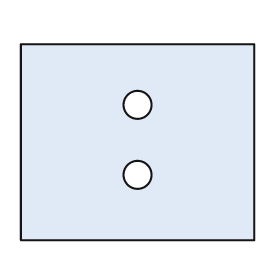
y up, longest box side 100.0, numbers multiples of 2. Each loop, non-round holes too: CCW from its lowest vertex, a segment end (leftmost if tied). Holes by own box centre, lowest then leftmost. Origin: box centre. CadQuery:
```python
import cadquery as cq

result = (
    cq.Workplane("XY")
    .moveTo(-50.0, -42.0)
    .lineTo(50.0, -42.0)
    .lineTo(50.0, 42.0)
    .lineTo(-50.0, 42.0)
    .close()
    .moveTo(0.0, -14.0)
    .circle(6.0)
    .moveTo(0.0, 16.0)
    .circle(6.0)
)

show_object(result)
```